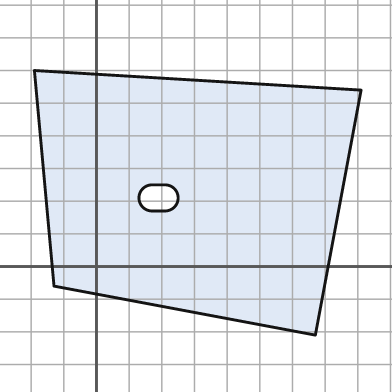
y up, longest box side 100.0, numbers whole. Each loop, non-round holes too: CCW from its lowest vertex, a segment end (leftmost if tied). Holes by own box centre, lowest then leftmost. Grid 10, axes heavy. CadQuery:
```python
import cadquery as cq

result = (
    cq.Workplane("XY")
    .moveTo(67.0, -21.0)
    .lineTo(81.0, 54.0)
    .lineTo(-19.0, 60.0)
    .lineTo(-13.0, -6.0)
    .close()
    .moveTo(17.0, 17.0)
    .lineTo(21.0, 17.0)
    .threePointArc((25.0, 21.0), (21.0, 25.0))
    .lineTo(17.0, 25.0)
    .threePointArc((13.0, 21.0), (17.0, 17.0))
    .close()
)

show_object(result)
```